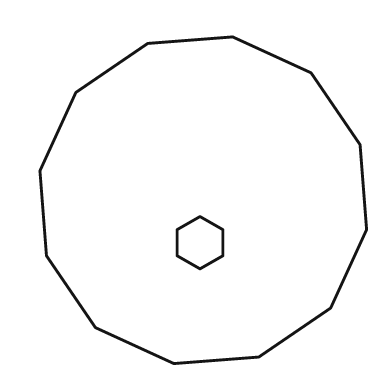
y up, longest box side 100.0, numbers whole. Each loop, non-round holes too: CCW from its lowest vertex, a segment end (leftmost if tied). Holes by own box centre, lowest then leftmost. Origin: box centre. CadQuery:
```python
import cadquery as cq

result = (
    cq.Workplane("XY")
    .moveTo(-9.0, -50.0)
    .lineTo(17.0, -48.0)
    .lineTo(39.0, -33.0)
    .lineTo(50.0, -9.0)
    .lineTo(48.0, 17.0)
    .lineTo(33.0, 39.0)
    .lineTo(9.0, 50.0)
    .lineTo(-17.0, 48.0)
    .lineTo(-39.0, 33.0)
    .lineTo(-50.0, 9.0)
    .lineTo(-48.0, -17.0)
    .lineTo(-33.0, -39.0)
    .close()
    .moveTo(-1.0, -21.0)
    .lineTo(6.0, -17.0)
    .lineTo(6.0, -9.0)
    .lineTo(-1.0, -5.0)
    .lineTo(-8.0, -9.0)
    .lineTo(-8.0, -17.0)
    .close()
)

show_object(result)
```